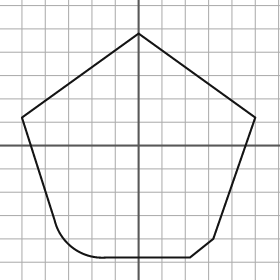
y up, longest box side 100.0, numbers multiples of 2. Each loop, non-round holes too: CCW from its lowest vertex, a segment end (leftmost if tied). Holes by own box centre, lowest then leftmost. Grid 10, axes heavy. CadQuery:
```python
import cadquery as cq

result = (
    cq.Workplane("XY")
    .moveTo(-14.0, -48.0)
    .lineTo(22.0, -48.0)
    .lineTo(32.0, -40.0)
    .lineTo(50.0, 12.0)
    .lineTo(0.0, 48.0)
    .lineTo(-50.0, 12.0)
    .lineTo(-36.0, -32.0)
    .threePointArc((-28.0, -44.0), (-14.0, -48.0))
    .close()
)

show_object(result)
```